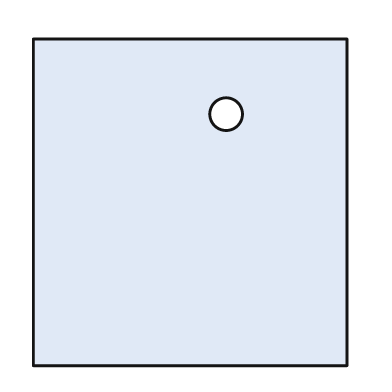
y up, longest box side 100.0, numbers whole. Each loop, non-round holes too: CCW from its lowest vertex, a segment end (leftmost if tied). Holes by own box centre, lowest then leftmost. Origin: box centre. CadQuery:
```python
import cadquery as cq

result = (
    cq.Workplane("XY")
    .moveTo(-48.0, -50.0)
    .lineTo(48.0, -50.0)
    .lineTo(48.0, 50.0)
    .lineTo(-48.0, 50.0)
    .close()
    .moveTo(11.0, 27.0)
    .circle(5.0)
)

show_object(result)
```